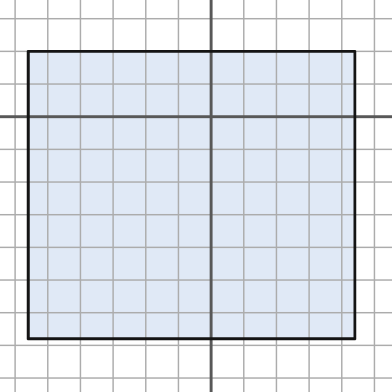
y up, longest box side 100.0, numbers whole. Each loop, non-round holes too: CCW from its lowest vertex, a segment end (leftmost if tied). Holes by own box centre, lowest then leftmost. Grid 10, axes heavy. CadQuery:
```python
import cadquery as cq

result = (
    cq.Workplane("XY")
    .moveTo(-56.0, -68.0)
    .lineTo(44.0, -68.0)
    .lineTo(44.0, 20.0)
    .lineTo(-56.0, 20.0)
    .close()
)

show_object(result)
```